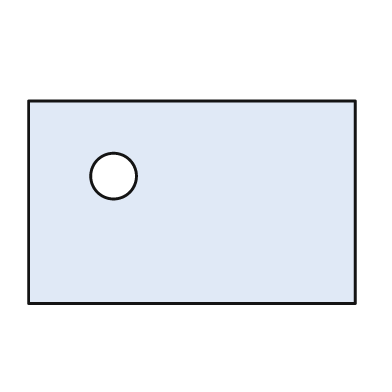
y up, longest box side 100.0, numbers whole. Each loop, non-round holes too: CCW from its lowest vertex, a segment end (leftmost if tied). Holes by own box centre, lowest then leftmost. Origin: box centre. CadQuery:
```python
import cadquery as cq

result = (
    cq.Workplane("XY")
    .moveTo(-50.0, -31.0)
    .lineTo(50.0, -31.0)
    .lineTo(50.0, 31.0)
    .lineTo(-50.0, 31.0)
    .close()
    .moveTo(-24.0, 8.0)
    .circle(7.0)
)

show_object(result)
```